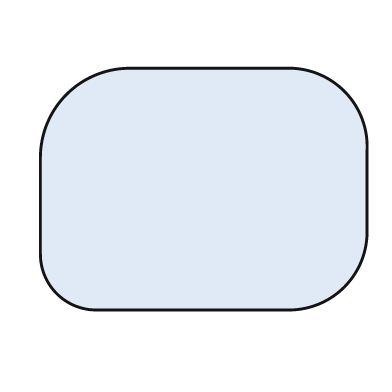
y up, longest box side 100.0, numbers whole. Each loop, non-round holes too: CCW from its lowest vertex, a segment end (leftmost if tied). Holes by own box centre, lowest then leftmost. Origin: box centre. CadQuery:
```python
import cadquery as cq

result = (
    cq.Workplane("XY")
    .moveTo(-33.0, -37.0)
    .lineTo(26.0, -37.0)
    .threePointArc((43.0, -30.0), (50.0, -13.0))
    .lineTo(50.0, 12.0)
    .threePointArc((43.0, 30.0), (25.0, 37.0))
    .lineTo(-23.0, 37.0)
    .threePointArc((-42.0, 29.0), (-50.0, 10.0))
    .lineTo(-50.0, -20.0)
    .threePointArc((-45.0, -32.0), (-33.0, -37.0))
    .close()
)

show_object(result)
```